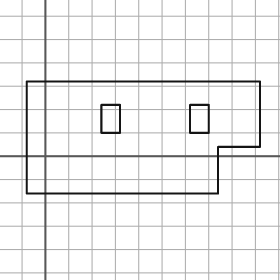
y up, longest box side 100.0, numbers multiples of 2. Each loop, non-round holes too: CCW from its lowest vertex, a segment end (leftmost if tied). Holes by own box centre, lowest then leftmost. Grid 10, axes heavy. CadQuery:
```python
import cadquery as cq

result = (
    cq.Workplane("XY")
    .moveTo(-8.0, -16.0)
    .lineTo(74.0, -16.0)
    .lineTo(74.0, 4.0)
    .lineTo(92.0, 4.0)
    .lineTo(92.0, 32.0)
    .lineTo(-8.0, 32.0)
    .close()
    .moveTo(24.0, 10.0)
    .lineTo(32.0, 10.0)
    .lineTo(32.0, 22.0)
    .lineTo(24.0, 22.0)
    .close()
    .moveTo(62.0, 10.0)
    .lineTo(70.0, 10.0)
    .lineTo(70.0, 22.0)
    .lineTo(62.0, 22.0)
    .close()
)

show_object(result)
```